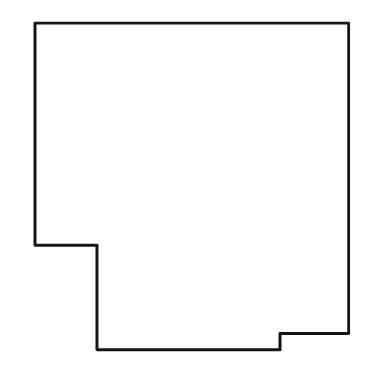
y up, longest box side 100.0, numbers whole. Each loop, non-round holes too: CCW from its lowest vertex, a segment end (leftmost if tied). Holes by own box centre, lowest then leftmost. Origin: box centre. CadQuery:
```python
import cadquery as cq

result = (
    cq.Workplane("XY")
    .moveTo(-29.0, -50.0)
    .lineTo(27.0, -50.0)
    .lineTo(27.0, -45.0)
    .lineTo(48.0, -45.0)
    .lineTo(48.0, 50.0)
    .lineTo(-48.0, 50.0)
    .lineTo(-48.0, -18.0)
    .lineTo(-29.0, -18.0)
    .close()
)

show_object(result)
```